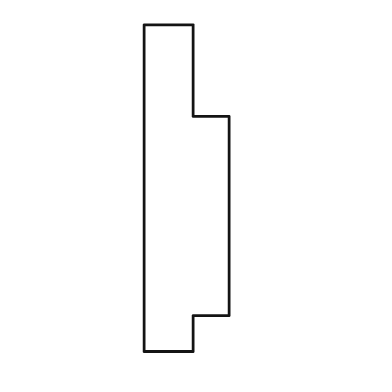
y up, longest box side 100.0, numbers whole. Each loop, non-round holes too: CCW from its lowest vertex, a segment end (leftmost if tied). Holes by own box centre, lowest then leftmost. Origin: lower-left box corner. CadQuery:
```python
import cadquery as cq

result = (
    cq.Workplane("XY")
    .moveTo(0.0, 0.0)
    .lineTo(15.0, 0.0)
    .lineTo(15.0, 11.0)
    .lineTo(26.0, 11.0)
    .lineTo(26.0, 72.0)
    .lineTo(15.0, 72.0)
    .lineTo(15.0, 100.0)
    .lineTo(0.0, 100.0)
    .close()
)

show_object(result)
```